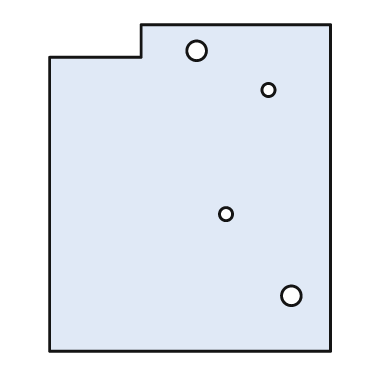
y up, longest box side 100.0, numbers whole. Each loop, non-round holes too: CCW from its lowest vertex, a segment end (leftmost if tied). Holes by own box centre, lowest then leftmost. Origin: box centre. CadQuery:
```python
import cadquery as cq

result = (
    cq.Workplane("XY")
    .moveTo(-43.0, -50.0)
    .lineTo(43.0, -50.0)
    .lineTo(43.0, 50.0)
    .lineTo(-15.0, 50.0)
    .lineTo(-15.0, 40.0)
    .lineTo(-43.0, 40.0)
    .close()
    .moveTo(31.0, -33.0)
    .circle(3.0)
    .moveTo(11.0, -8.0)
    .circle(2.0)
    .moveTo(24.0, 30.0)
    .circle(2.0)
    .moveTo(2.0, 42.0)
    .circle(3.0)
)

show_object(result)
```